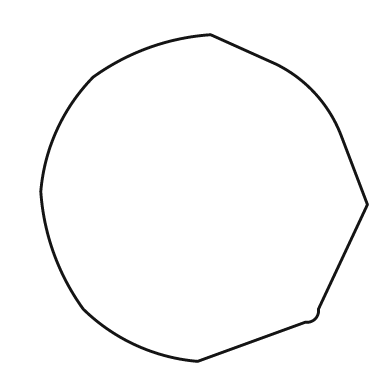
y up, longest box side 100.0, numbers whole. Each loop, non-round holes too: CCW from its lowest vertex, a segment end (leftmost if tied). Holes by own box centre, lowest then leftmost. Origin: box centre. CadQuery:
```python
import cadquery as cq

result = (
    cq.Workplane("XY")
    .moveTo(-2.0, -50.0)
    .lineTo(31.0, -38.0)
    .threePointArc((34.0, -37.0), (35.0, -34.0))
    .lineTo(50.0, -2.0)
    .lineTo(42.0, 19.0)
    .threePointArc((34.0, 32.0), (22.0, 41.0))
    .lineTo(2.0, 50.0)
    .threePointArc((-17.0, 46.0), (-34.0, 37.0))
    .threePointArc((-45.0, 21.0), (-50.0, 2.0))
    .threePointArc((-46.0, -17.0), (-37.0, -34.0))
    .threePointArc((-21.0, -45.0), (-2.0, -50.0))
    .close()
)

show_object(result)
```